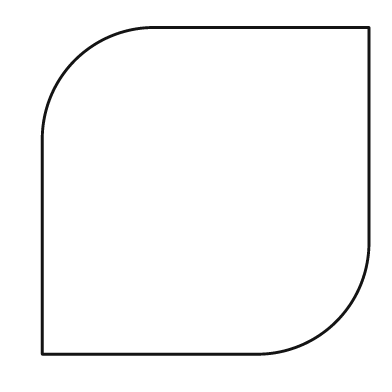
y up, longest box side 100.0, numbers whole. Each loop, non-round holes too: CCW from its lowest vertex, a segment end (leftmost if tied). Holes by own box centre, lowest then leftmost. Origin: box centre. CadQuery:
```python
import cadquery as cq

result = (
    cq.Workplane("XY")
    .moveTo(-50.0, -50.0)
    .lineTo(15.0, -50.0)
    .threePointArc((40.0, -40.0), (50.0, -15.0))
    .lineTo(50.0, 50.0)
    .lineTo(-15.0, 50.0)
    .threePointArc((-40.0, 40.0), (-50.0, 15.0))
    .close()
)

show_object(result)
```